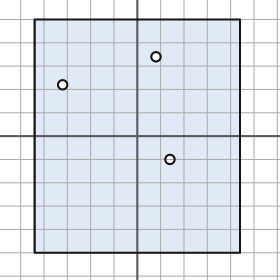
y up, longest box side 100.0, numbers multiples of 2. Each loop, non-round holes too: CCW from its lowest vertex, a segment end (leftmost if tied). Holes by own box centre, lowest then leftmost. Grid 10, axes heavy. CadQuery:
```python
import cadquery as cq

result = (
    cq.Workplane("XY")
    .moveTo(-44.0, -50.0)
    .lineTo(44.0, -50.0)
    .lineTo(44.0, 50.0)
    .lineTo(-44.0, 50.0)
    .close()
    .moveTo(14.0, -10.0)
    .circle(2.0)
    .moveTo(-32.0, 22.0)
    .circle(2.0)
    .moveTo(8.0, 34.0)
    .circle(2.0)
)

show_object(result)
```